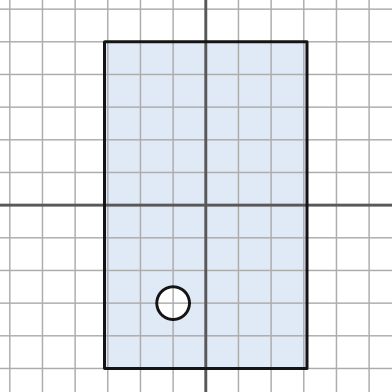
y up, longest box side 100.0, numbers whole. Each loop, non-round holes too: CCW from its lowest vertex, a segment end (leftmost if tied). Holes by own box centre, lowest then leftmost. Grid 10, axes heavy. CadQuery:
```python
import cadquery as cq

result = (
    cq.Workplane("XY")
    .moveTo(-31.0, -50.0)
    .lineTo(31.0, -50.0)
    .lineTo(31.0, 50.0)
    .lineTo(-31.0, 50.0)
    .close()
    .moveTo(-10.0, -30.0)
    .circle(5.0)
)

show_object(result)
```